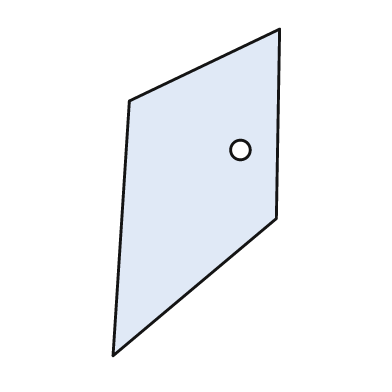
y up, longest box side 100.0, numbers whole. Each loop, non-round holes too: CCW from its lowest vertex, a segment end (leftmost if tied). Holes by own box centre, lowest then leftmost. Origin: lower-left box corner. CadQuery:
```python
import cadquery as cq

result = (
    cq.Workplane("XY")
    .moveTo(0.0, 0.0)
    .lineTo(50.0, 42.0)
    .lineTo(51.0, 100.0)
    .lineTo(5.0, 78.0)
    .close()
    .moveTo(39.0, 63.0)
    .circle(3.0)
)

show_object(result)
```